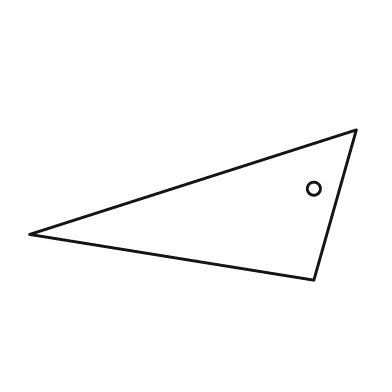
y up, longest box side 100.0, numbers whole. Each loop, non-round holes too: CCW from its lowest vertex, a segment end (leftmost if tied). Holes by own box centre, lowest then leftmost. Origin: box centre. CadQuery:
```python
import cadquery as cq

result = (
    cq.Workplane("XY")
    .moveTo(37.0, -23.0)
    .lineTo(50.0, 23.0)
    .lineTo(-50.0, -9.0)
    .close()
    .moveTo(37.0, 5.0)
    .circle(2.0)
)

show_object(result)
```